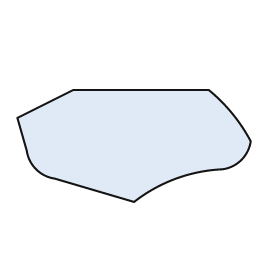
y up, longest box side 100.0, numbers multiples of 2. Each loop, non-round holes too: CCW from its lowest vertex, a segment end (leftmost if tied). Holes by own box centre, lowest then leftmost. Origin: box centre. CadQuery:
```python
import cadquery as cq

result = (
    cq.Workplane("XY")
    .moveTo(0.0, -24.0)
    .threePointArc((18.0, -14.0), (38.0, -10.0))
    .threePointArc((46.0, -6.0), (50.0, 2.0))
    .threePointArc((42.0, 14.0), (32.0, 24.0))
    .lineTo(-26.0, 24.0)
    .lineTo(-50.0, 12.0)
    .lineTo(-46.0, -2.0)
    .threePointArc((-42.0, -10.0), (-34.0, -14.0))
    .close()
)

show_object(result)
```